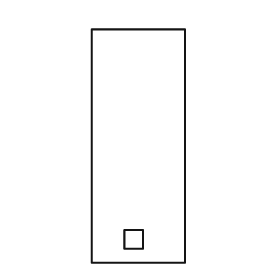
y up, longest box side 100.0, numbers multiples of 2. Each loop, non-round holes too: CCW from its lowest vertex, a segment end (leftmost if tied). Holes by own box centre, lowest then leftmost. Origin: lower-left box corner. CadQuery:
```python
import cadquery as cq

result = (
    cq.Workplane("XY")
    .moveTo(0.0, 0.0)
    .lineTo(40.0, 0.0)
    .lineTo(40.0, 100.0)
    .lineTo(0.0, 100.0)
    .close()
    .moveTo(14.0, 6.0)
    .lineTo(22.0, 6.0)
    .lineTo(22.0, 14.0)
    .lineTo(14.0, 14.0)
    .close()
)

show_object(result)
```